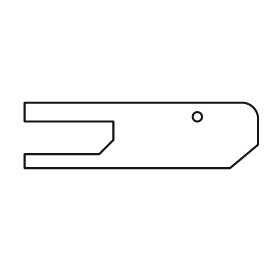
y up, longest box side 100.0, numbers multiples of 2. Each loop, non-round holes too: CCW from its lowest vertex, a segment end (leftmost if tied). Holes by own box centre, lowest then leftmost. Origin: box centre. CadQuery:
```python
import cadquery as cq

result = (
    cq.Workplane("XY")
    .moveTo(-50.0, -14.0)
    .lineTo(38.0, -14.0)
    .lineTo(50.0, -4.0)
    .lineTo(50.0, 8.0)
    .threePointArc((48.0, 12.0), (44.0, 14.0))
    .lineTo(-50.0, 14.0)
    .lineTo(-50.0, 6.0)
    .lineTo(-12.0, 6.0)
    .lineTo(-12.0, -2.0)
    .lineTo(-18.0, -8.0)
    .lineTo(-50.0, -8.0)
    .close()
    .moveTo(24.0, 8.0)
    .circle(2.0)
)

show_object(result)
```